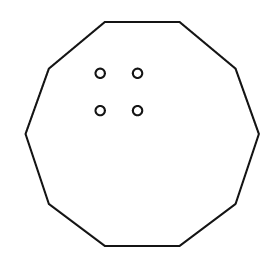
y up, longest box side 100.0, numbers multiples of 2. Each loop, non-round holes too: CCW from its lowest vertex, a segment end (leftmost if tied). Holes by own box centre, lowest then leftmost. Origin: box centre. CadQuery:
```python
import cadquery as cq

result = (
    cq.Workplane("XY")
    .moveTo(-16.0, -48.0)
    .lineTo(16.0, -48.0)
    .lineTo(40.0, -30.0)
    .lineTo(50.0, 0.0)
    .lineTo(40.0, 28.0)
    .lineTo(16.0, 48.0)
    .lineTo(-16.0, 48.0)
    .lineTo(-40.0, 28.0)
    .lineTo(-50.0, 0.0)
    .lineTo(-40.0, -30.0)
    .close()
    .moveTo(-18.0, 10.0)
    .circle(2.0)
    .moveTo(-2.0, 10.0)
    .circle(2.0)
    .moveTo(-18.0, 26.0)
    .circle(2.0)
    .moveTo(-2.0, 26.0)
    .circle(2.0)
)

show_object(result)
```